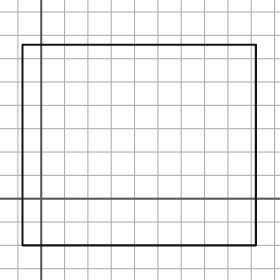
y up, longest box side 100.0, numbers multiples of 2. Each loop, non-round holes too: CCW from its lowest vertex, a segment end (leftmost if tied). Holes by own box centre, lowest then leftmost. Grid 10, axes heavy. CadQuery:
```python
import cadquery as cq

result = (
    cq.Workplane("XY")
    .moveTo(-8.0, -20.0)
    .lineTo(92.0, -20.0)
    .lineTo(92.0, 66.0)
    .lineTo(-8.0, 66.0)
    .close()
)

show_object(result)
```